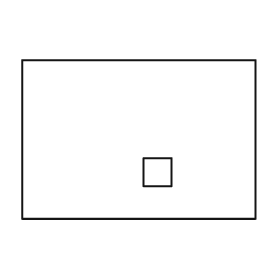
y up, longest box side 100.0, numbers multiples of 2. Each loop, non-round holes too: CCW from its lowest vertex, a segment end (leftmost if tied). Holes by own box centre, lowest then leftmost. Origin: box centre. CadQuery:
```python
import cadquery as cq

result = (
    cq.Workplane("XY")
    .moveTo(-50.0, -34.0)
    .lineTo(50.0, -34.0)
    .lineTo(50.0, 34.0)
    .lineTo(-50.0, 34.0)
    .close()
    .moveTo(2.0, -20.0)
    .lineTo(14.0, -20.0)
    .lineTo(14.0, -8.0)
    .lineTo(2.0, -8.0)
    .close()
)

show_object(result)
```